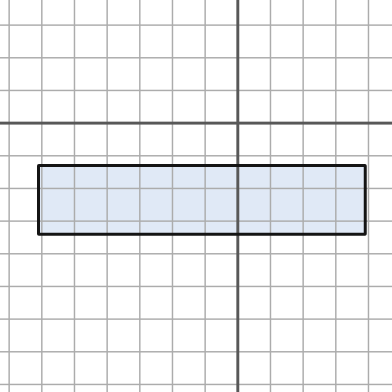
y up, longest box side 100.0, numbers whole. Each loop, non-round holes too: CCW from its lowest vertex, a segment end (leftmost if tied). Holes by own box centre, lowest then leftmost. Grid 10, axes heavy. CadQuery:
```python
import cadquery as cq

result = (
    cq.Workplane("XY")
    .moveTo(-61.0, -34.0)
    .lineTo(39.0, -34.0)
    .lineTo(39.0, -13.0)
    .lineTo(-61.0, -13.0)
    .close()
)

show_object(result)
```